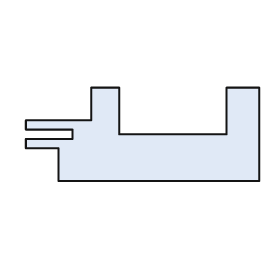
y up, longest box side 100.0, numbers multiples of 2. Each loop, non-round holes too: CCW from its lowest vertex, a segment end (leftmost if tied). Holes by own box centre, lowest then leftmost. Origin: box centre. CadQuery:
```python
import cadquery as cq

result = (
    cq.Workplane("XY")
    .moveTo(-36.0, -20.0)
    .lineTo(50.0, -20.0)
    .lineTo(50.0, 20.0)
    .lineTo(36.0, 20.0)
    .lineTo(36.0, 0.0)
    .lineTo(-10.0, 0.0)
    .lineTo(-10.0, 20.0)
    .lineTo(-22.0, 20.0)
    .lineTo(-22.0, 6.0)
    .lineTo(-50.0, 6.0)
    .lineTo(-50.0, 2.0)
    .lineTo(-30.0, 2.0)
    .lineTo(-30.0, -2.0)
    .lineTo(-50.0, -2.0)
    .lineTo(-50.0, -6.0)
    .lineTo(-36.0, -6.0)
    .close()
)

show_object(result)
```